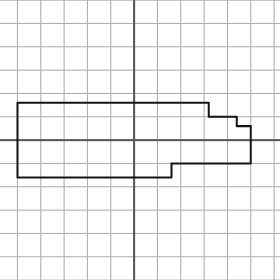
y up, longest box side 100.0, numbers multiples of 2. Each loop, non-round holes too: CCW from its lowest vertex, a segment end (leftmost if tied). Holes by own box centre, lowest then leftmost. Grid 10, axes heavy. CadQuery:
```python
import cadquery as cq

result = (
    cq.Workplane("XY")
    .moveTo(-50.0, -16.0)
    .lineTo(16.0, -16.0)
    .lineTo(16.0, -10.0)
    .lineTo(50.0, -10.0)
    .lineTo(50.0, 6.0)
    .lineTo(44.0, 6.0)
    .lineTo(44.0, 10.0)
    .lineTo(32.0, 10.0)
    .lineTo(32.0, 16.0)
    .lineTo(-50.0, 16.0)
    .close()
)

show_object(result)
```